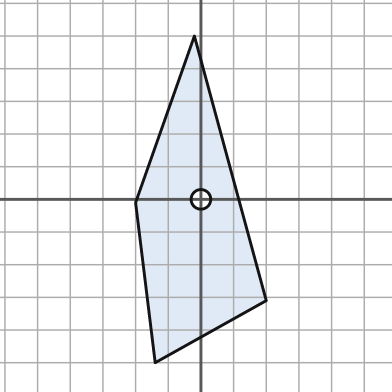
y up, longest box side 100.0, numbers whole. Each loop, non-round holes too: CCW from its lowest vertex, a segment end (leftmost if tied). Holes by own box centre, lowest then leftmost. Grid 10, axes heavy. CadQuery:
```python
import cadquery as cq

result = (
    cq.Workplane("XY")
    .moveTo(-14.0, -50.0)
    .lineTo(20.0, -31.0)
    .lineTo(-2.0, 50.0)
    .lineTo(-20.0, -1.0)
    .close()
    .moveTo(0.0, 0.0)
    .circle(3.0)
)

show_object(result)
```